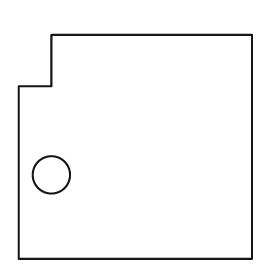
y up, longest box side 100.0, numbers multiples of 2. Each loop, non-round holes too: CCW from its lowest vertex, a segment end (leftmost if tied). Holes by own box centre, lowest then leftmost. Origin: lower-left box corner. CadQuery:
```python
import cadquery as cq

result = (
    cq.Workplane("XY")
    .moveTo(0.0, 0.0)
    .lineTo(100.0, 0.0)
    .lineTo(100.0, 96.0)
    .lineTo(14.0, 96.0)
    .lineTo(14.0, 74.0)
    .lineTo(0.0, 74.0)
    .close()
    .moveTo(14.0, 36.0)
    .circle(8.0)
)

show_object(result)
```